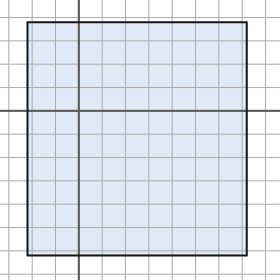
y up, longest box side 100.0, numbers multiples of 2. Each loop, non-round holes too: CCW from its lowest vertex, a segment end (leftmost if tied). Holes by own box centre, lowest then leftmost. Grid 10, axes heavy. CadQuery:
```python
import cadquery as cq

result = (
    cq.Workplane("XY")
    .moveTo(-22.0, -62.0)
    .lineTo(72.0, -62.0)
    .lineTo(72.0, 38.0)
    .lineTo(-22.0, 38.0)
    .close()
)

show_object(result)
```